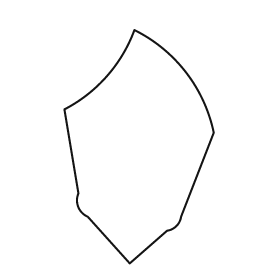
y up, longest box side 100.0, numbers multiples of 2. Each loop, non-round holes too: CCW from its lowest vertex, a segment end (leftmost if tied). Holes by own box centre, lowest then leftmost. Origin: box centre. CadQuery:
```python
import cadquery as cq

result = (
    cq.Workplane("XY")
    .moveTo(-4.0, -50.0)
    .lineTo(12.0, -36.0)
    .threePointArc((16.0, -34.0), (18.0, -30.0))
    .lineTo(32.0, 6.0)
    .threePointArc((20.0, 32.0), (-2.0, 50.0))
    .threePointArc((-14.0, 30.0), (-32.0, 16.0))
    .lineTo(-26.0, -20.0)
    .threePointArc((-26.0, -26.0), (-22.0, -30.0))
    .close()
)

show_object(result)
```